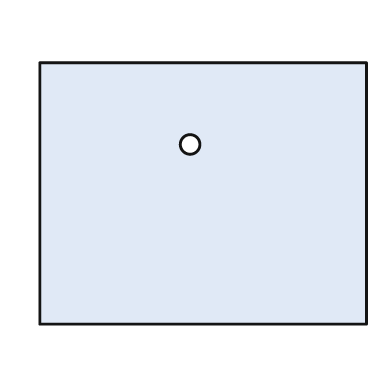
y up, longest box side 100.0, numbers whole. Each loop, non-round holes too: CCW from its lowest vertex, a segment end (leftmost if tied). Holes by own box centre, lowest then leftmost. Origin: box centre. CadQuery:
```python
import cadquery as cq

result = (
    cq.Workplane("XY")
    .moveTo(-50.0, -40.0)
    .lineTo(50.0, -40.0)
    .lineTo(50.0, 40.0)
    .lineTo(-50.0, 40.0)
    .close()
    .moveTo(-4.0, 15.0)
    .circle(3.0)
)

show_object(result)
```